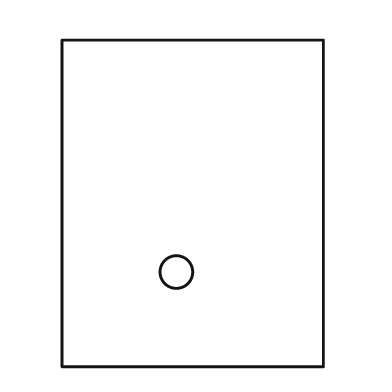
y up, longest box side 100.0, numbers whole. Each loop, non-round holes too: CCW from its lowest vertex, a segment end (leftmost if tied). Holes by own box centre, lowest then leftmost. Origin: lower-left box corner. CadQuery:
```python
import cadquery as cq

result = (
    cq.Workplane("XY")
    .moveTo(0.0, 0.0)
    .lineTo(80.0, 0.0)
    .lineTo(80.0, 100.0)
    .lineTo(0.0, 100.0)
    .close()
    .moveTo(35.0, 29.0)
    .circle(5.0)
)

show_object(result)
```